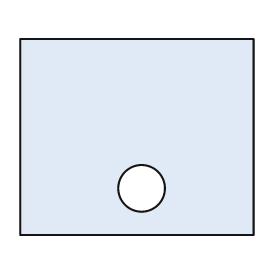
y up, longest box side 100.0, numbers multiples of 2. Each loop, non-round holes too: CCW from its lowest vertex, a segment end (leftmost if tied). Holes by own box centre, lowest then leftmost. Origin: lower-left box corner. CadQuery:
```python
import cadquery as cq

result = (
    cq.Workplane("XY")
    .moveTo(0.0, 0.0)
    .lineTo(100.0, 0.0)
    .lineTo(100.0, 84.0)
    .lineTo(0.0, 84.0)
    .close()
    .moveTo(52.0, 20.0)
    .circle(10.0)
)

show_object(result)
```